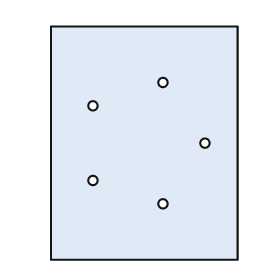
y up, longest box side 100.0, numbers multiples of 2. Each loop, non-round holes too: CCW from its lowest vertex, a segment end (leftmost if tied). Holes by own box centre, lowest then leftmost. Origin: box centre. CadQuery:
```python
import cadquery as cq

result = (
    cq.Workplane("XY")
    .moveTo(-40.0, -50.0)
    .lineTo(40.0, -50.0)
    .lineTo(40.0, 50.0)
    .lineTo(-40.0, 50.0)
    .close()
    .moveTo(8.0, -26.0)
    .circle(2.0)
    .moveTo(-22.0, -16.0)
    .circle(2.0)
    .moveTo(26.0, 0.0)
    .circle(2.0)
    .moveTo(-22.0, 16.0)
    .circle(2.0)
    .moveTo(8.0, 26.0)
    .circle(2.0)
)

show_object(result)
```